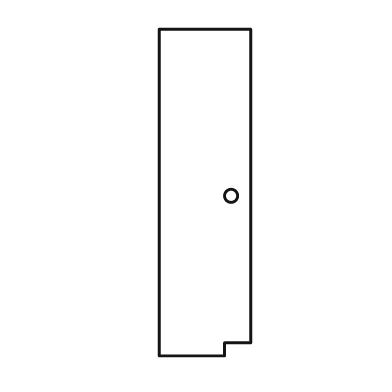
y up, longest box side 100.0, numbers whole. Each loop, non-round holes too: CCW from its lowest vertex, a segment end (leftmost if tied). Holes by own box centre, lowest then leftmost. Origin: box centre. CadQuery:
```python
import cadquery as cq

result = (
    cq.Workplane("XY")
    .moveTo(-14.0, -50.0)
    .lineTo(6.0, -50.0)
    .lineTo(6.0, -46.0)
    .lineTo(14.0, -46.0)
    .lineTo(14.0, 50.0)
    .lineTo(-14.0, 50.0)
    .close()
    .moveTo(8.0, -1.0)
    .circle(2.0)
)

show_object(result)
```